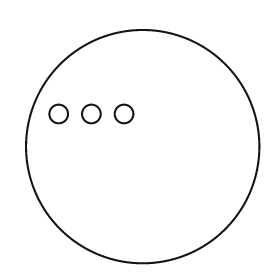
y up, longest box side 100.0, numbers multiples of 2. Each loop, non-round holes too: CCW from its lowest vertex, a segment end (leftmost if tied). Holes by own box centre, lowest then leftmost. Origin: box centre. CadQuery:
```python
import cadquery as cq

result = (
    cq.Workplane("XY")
    .moveTo(0.0, 0.0)
    .circle(50.0)
    .moveTo(-36.0, 14.0)
    .circle(4.0)
    .moveTo(-22.0, 14.0)
    .circle(4.0)
    .moveTo(-8.0, 14.0)
    .circle(4.0)
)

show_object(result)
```